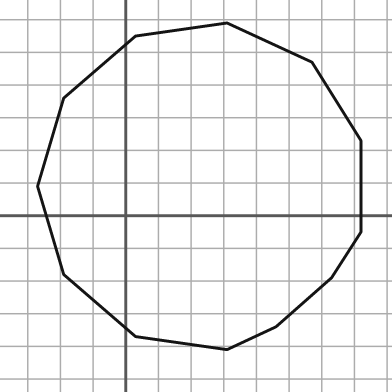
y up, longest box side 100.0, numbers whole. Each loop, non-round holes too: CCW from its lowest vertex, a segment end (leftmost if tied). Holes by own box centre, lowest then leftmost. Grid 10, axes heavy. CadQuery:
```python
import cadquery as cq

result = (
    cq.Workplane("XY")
    .moveTo(31.0, -41.0)
    .lineTo(46.0, -34.0)
    .lineTo(63.0, -19.0)
    .lineTo(72.0, -5.0)
    .lineTo(72.0, 23.0)
    .lineTo(57.0, 47.0)
    .lineTo(31.0, 59.0)
    .lineTo(3.0, 55.0)
    .lineTo(-19.0, 36.0)
    .lineTo(-27.0, 9.0)
    .lineTo(-19.0, -18.0)
    .lineTo(3.0, -37.0)
    .close()
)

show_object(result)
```